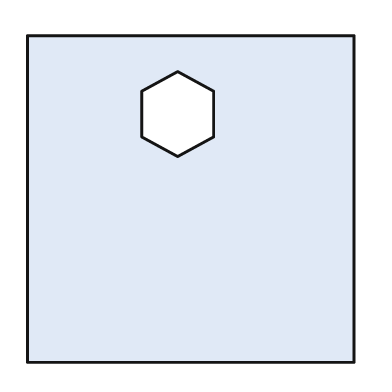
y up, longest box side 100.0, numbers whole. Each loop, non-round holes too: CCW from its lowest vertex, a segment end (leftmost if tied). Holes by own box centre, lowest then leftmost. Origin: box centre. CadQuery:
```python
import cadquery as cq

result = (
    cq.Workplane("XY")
    .moveTo(-50.0, -50.0)
    .lineTo(50.0, -50.0)
    .lineTo(50.0, 50.0)
    .lineTo(-50.0, 50.0)
    .close()
    .moveTo(-4.0, 13.0)
    .lineTo(7.0, 19.0)
    .lineTo(7.0, 33.0)
    .lineTo(-4.0, 39.0)
    .lineTo(-15.0, 33.0)
    .lineTo(-15.0, 19.0)
    .close()
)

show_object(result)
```